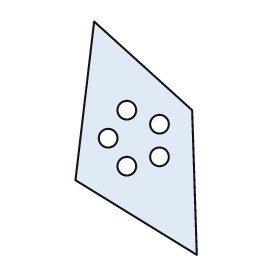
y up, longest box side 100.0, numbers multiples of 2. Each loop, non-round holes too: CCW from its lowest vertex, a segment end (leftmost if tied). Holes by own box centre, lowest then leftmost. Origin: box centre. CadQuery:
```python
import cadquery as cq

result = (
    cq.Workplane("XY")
    .moveTo(26.0, -50.0)
    .lineTo(24.0, 12.0)
    .lineTo(-18.0, 50.0)
    .lineTo(-26.0, -18.0)
    .close()
    .moveTo(-4.0, -12.0)
    .circle(4.0)
    .moveTo(10.0, -8.0)
    .circle(4.0)
    .moveTo(-12.0, 0.0)
    .circle(4.0)
    .moveTo(10.0, 6.0)
    .circle(4.0)
    .moveTo(-4.0, 12.0)
    .circle(4.0)
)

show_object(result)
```